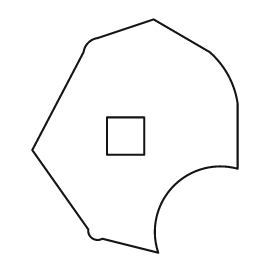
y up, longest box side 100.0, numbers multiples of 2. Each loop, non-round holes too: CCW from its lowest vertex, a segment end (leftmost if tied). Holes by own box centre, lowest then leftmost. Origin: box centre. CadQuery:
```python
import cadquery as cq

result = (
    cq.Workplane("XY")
    .moveTo(10.0, -50.0)
    .threePointArc((16.0, -22.0), (44.0, -14.0))
    .lineTo(44.0, 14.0)
    .threePointArc((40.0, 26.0), (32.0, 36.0))
    .lineTo(8.0, 50.0)
    .lineTo(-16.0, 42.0)
    .threePointArc((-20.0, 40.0), (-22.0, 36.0))
    .lineTo(-44.0, -6.0)
    .lineTo(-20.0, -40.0)
    .threePointArc((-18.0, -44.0), (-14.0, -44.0))
    .close()
    .moveTo(-12.0, -8.0)
    .lineTo(4.0, -8.0)
    .lineTo(4.0, 8.0)
    .lineTo(-12.0, 8.0)
    .close()
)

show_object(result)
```